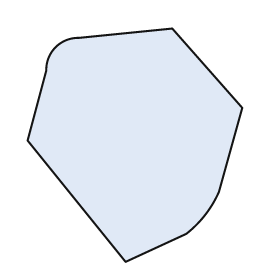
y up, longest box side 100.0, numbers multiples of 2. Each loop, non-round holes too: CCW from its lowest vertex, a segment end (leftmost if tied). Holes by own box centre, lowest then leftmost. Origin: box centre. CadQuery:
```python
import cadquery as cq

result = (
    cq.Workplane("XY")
    .moveTo(-4.0, -50.0)
    .lineTo(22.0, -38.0)
    .threePointArc((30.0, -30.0), (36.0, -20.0))
    .lineTo(46.0, 16.0)
    .lineTo(16.0, 50.0)
    .lineTo(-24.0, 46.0)
    .threePointArc((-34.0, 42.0), (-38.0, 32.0))
    .lineTo(-46.0, 2.0)
    .close()
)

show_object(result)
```